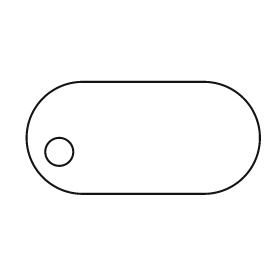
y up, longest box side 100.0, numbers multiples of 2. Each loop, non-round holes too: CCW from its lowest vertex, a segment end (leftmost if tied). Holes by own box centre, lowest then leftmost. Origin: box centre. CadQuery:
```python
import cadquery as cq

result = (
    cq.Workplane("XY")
    .moveTo(-26.0, -24.0)
    .lineTo(26.0, -24.0)
    .threePointArc((50.0, 0.0), (26.0, 24.0))
    .lineTo(-26.0, 24.0)
    .threePointArc((-50.0, 0.0), (-26.0, -24.0))
    .close()
    .moveTo(-36.0, -6.0)
    .circle(6.0)
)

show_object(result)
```